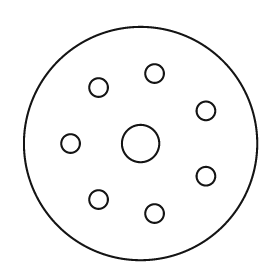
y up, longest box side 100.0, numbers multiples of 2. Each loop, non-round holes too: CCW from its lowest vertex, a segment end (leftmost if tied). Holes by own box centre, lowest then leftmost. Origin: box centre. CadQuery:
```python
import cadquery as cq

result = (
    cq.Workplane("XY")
    .moveTo(0.0, 0.0)
    .circle(50.0)
    .moveTo(6.0, -30.0)
    .circle(4.0)
    .moveTo(-18.0, -24.0)
    .circle(4.0)
    .moveTo(28.0, -14.0)
    .circle(4.0)
    .moveTo(-30.0, 0.0)
    .circle(4.0)
    .moveTo(0.0, 0.0)
    .circle(8.0)
    .moveTo(28.0, 14.0)
    .circle(4.0)
    .moveTo(-18.0, 24.0)
    .circle(4.0)
    .moveTo(6.0, 30.0)
    .circle(4.0)
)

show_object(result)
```